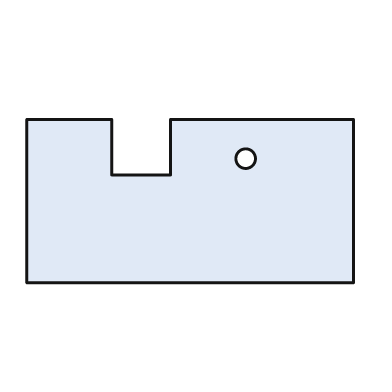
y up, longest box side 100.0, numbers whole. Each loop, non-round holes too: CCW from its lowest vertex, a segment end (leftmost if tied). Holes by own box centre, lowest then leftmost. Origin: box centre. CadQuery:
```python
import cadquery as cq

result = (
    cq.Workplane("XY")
    .moveTo(-50.0, -25.0)
    .lineTo(50.0, -25.0)
    .lineTo(50.0, 25.0)
    .lineTo(-6.0, 25.0)
    .lineTo(-6.0, 8.0)
    .lineTo(-24.0, 8.0)
    .lineTo(-24.0, 25.0)
    .lineTo(-50.0, 25.0)
    .close()
    .moveTo(17.0, 13.0)
    .circle(3.0)
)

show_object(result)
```